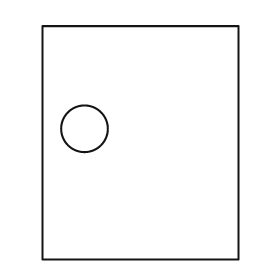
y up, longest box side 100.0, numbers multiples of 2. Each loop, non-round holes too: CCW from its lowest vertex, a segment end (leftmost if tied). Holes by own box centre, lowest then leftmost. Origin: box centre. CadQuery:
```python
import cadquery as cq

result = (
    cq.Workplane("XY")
    .moveTo(-42.0, -50.0)
    .lineTo(42.0, -50.0)
    .lineTo(42.0, 50.0)
    .lineTo(-42.0, 50.0)
    .close()
    .moveTo(-24.0, 6.0)
    .circle(10.0)
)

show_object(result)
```